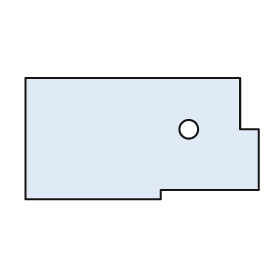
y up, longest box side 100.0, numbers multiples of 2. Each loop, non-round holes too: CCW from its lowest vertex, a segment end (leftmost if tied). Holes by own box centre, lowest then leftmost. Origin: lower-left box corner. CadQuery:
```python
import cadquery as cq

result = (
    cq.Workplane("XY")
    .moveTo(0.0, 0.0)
    .lineTo(58.0, 0.0)
    .lineTo(58.0, 4.0)
    .lineTo(100.0, 4.0)
    .lineTo(100.0, 30.0)
    .lineTo(92.0, 30.0)
    .lineTo(92.0, 52.0)
    .lineTo(0.0, 52.0)
    .close()
    .moveTo(70.0, 30.0)
    .circle(4.0)
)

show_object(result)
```